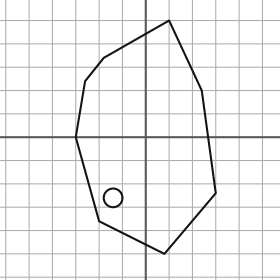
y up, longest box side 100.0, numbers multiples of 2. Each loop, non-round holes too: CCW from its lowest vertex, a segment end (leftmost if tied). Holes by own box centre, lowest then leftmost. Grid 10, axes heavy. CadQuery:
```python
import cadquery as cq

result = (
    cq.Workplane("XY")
    .moveTo(8.0, -50.0)
    .lineTo(30.0, -24.0)
    .lineTo(24.0, 20.0)
    .lineTo(10.0, 50.0)
    .lineTo(-18.0, 34.0)
    .lineTo(-26.0, 24.0)
    .lineTo(-30.0, 0.0)
    .lineTo(-20.0, -36.0)
    .close()
    .moveTo(-14.0, -26.0)
    .circle(4.0)
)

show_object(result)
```